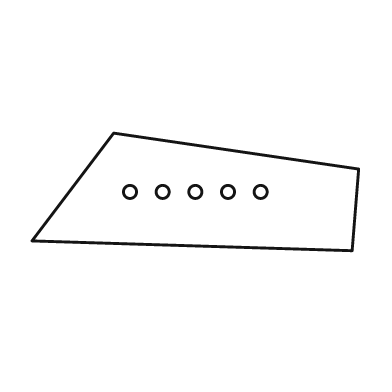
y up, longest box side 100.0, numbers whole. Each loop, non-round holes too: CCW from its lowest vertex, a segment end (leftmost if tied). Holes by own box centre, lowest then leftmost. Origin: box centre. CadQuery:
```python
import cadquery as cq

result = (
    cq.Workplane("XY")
    .moveTo(48.0, -18.0)
    .lineTo(50.0, 7.0)
    .lineTo(-25.0, 18.0)
    .lineTo(-50.0, -15.0)
    .close()
    .moveTo(-20.0, 0.0)
    .circle(2.0)
    .moveTo(-10.0, 0.0)
    .circle(2.0)
    .moveTo(0.0, 0.0)
    .circle(2.0)
    .moveTo(10.0, 0.0)
    .circle(2.0)
    .moveTo(20.0, 0.0)
    .circle(2.0)
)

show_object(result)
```